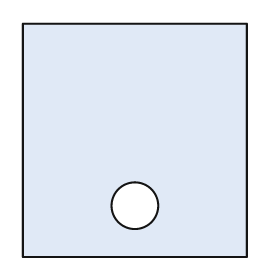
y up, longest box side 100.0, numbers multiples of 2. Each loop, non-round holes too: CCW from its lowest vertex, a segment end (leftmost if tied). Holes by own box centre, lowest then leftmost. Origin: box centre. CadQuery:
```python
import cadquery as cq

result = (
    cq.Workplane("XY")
    .moveTo(-48.0, -50.0)
    .lineTo(48.0, -50.0)
    .lineTo(48.0, 50.0)
    .lineTo(-48.0, 50.0)
    .close()
    .moveTo(0.0, -28.0)
    .circle(10.0)
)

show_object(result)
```